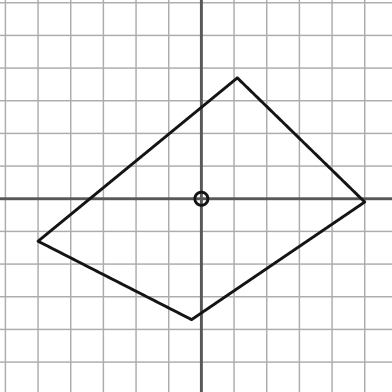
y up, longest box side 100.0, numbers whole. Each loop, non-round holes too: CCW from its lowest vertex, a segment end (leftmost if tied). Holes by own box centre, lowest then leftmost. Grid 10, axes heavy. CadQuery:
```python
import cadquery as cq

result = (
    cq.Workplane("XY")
    .moveTo(-3.0, -37.0)
    .lineTo(50.0, -1.0)
    .lineTo(11.0, 37.0)
    .lineTo(-50.0, -13.0)
    .close()
    .moveTo(0.0, 0.0)
    .circle(2.0)
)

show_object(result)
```